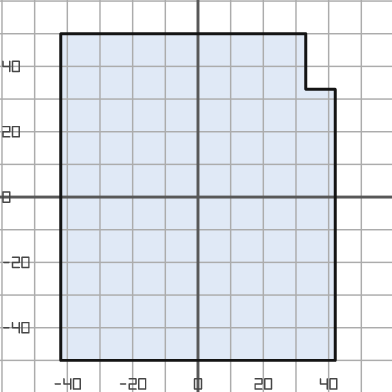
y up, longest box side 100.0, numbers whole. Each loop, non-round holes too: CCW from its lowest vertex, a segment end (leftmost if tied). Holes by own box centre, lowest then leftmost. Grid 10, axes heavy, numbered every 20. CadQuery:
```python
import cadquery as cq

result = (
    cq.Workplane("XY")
    .moveTo(-42.0, -50.0)
    .lineTo(42.0, -50.0)
    .lineTo(42.0, 33.0)
    .lineTo(33.0, 33.0)
    .lineTo(33.0, 50.0)
    .lineTo(-42.0, 50.0)
    .close()
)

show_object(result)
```